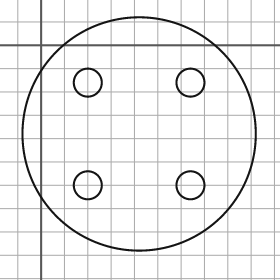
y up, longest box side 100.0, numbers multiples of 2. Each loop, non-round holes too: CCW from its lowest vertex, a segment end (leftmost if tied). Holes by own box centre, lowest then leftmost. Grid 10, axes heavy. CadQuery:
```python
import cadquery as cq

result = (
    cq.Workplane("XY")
    .moveTo(42.0, -38.0)
    .circle(50.0)
    .moveTo(20.0, -60.0)
    .circle(6.0)
    .moveTo(64.0, -60.0)
    .circle(6.0)
    .moveTo(20.0, -16.0)
    .circle(6.0)
    .moveTo(64.0, -16.0)
    .circle(6.0)
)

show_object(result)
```